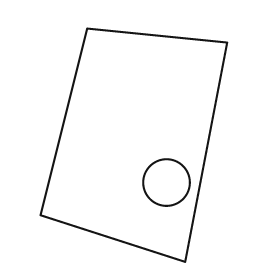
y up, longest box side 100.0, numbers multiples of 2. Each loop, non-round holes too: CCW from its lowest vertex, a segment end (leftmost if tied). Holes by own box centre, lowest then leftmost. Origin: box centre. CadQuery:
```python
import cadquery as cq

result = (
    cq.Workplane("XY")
    .moveTo(22.0, -50.0)
    .lineTo(40.0, 44.0)
    .lineTo(-20.0, 50.0)
    .lineTo(-40.0, -30.0)
    .close()
    .moveTo(14.0, -16.0)
    .circle(10.0)
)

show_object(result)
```